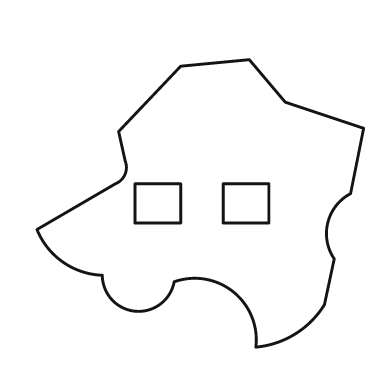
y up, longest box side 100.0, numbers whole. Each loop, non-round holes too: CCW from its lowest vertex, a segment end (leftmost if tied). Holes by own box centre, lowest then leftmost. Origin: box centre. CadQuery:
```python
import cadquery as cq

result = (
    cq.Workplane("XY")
    .moveTo(17.0, -44.0)
    .threePointArc((29.0, -40.0), (38.0, -31.0))
    .lineTo(41.0, -17.0)
    .threePointArc((39.0, -6.0), (46.0, 3.0))
    .lineTo(50.0, 23.0)
    .lineTo(26.0, 31.0)
    .lineTo(15.0, 44.0)
    .lineTo(-6.0, 42.0)
    .lineTo(-25.0, 22.0)
    .lineTo(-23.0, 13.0)
    .threePointArc((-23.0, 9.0), (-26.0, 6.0))
    .lineTo(-50.0, -8.0)
    .threePointArc((-42.0, -18.0), (-30.0, -22.0))
    .threePointArc((-20.0, -33.0), (-8.0, -24.0))
    .threePointArc((10.0, -27.0), (17.0, -44.0))
    .close()
    .moveTo(-20.0, -6.0)
    .lineTo(-6.0, -6.0)
    .lineTo(-6.0, 6.0)
    .lineTo(-20.0, 6.0)
    .close()
    .moveTo(7.0, -6.0)
    .lineTo(21.0, -6.0)
    .lineTo(21.0, 6.0)
    .lineTo(7.0, 6.0)
    .close()
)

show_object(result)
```